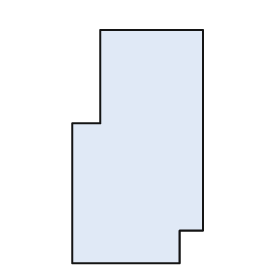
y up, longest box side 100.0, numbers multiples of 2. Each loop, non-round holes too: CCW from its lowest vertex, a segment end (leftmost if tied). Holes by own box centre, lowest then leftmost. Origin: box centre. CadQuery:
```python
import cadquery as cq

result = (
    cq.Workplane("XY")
    .moveTo(-28.0, -50.0)
    .lineTo(18.0, -50.0)
    .lineTo(18.0, -36.0)
    .lineTo(28.0, -36.0)
    .lineTo(28.0, 50.0)
    .lineTo(-16.0, 50.0)
    .lineTo(-16.0, 10.0)
    .lineTo(-28.0, 10.0)
    .close()
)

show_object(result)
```